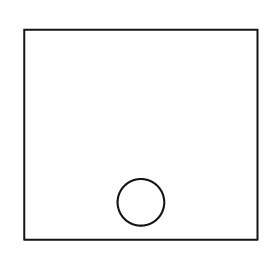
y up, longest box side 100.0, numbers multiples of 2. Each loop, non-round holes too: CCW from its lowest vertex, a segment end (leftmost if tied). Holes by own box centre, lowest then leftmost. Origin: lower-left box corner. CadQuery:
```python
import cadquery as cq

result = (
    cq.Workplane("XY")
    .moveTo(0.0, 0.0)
    .lineTo(100.0, 0.0)
    .lineTo(100.0, 90.0)
    .lineTo(0.0, 90.0)
    .close()
    .moveTo(50.0, 16.0)
    .circle(10.0)
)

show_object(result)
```